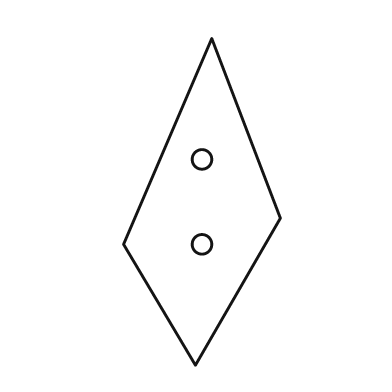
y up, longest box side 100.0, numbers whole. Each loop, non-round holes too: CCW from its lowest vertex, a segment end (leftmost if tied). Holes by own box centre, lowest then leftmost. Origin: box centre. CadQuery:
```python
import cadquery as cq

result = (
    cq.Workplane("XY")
    .moveTo(-2.0, -50.0)
    .lineTo(24.0, -5.0)
    .lineTo(3.0, 50.0)
    .lineTo(-24.0, -13.0)
    .close()
    .moveTo(0.0, -13.0)
    .circle(3.0)
    .moveTo(0.0, 13.0)
    .circle(3.0)
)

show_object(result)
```